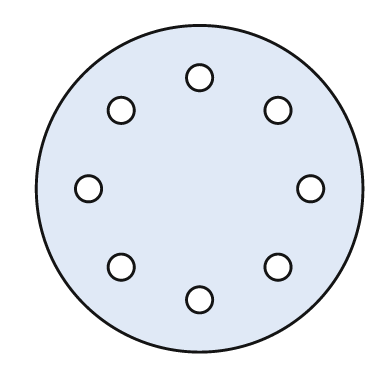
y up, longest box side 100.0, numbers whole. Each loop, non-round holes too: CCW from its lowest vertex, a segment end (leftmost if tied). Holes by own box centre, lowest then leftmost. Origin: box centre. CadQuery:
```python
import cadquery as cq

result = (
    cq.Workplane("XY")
    .moveTo(0.0, 0.0)
    .circle(50.0)
    .moveTo(0.0, -34.0)
    .circle(4.0)
    .moveTo(-24.0, -24.0)
    .circle(4.0)
    .moveTo(24.0, -24.0)
    .circle(4.0)
    .moveTo(-34.0, 0.0)
    .circle(4.0)
    .moveTo(34.0, 0.0)
    .circle(4.0)
    .moveTo(-24.0, 24.0)
    .circle(4.0)
    .moveTo(24.0, 24.0)
    .circle(4.0)
    .moveTo(0.0, 34.0)
    .circle(4.0)
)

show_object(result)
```